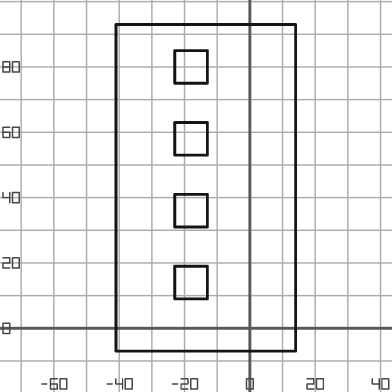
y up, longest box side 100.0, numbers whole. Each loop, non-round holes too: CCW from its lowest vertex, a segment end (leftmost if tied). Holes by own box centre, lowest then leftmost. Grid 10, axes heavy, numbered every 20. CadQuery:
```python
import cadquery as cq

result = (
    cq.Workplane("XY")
    .moveTo(-41.0, -7.0)
    .lineTo(14.0, -7.0)
    .lineTo(14.0, 93.0)
    .lineTo(-41.0, 93.0)
    .close()
    .moveTo(-23.0, 9.0)
    .lineTo(-13.0, 9.0)
    .lineTo(-13.0, 19.0)
    .lineTo(-23.0, 19.0)
    .close()
    .moveTo(-23.0, 31.0)
    .lineTo(-13.0, 31.0)
    .lineTo(-13.0, 41.0)
    .lineTo(-23.0, 41.0)
    .close()
    .moveTo(-23.0, 53.0)
    .lineTo(-13.0, 53.0)
    .lineTo(-13.0, 63.0)
    .lineTo(-23.0, 63.0)
    .close()
    .moveTo(-23.0, 75.0)
    .lineTo(-13.0, 75.0)
    .lineTo(-13.0, 85.0)
    .lineTo(-23.0, 85.0)
    .close()
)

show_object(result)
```